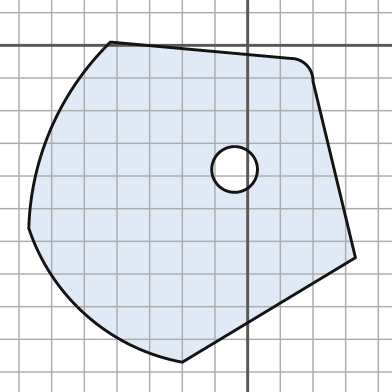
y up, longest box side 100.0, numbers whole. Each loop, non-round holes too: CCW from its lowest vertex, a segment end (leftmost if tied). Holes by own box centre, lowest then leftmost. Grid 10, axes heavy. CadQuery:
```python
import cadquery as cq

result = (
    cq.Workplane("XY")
    .moveTo(-20.0, -97.0)
    .lineTo(33.0, -65.0)
    .lineTo(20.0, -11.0)
    .threePointArc((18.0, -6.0), (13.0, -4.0))
    .lineTo(-42.0, 1.0)
    .threePointArc((-60.0, -25.0), (-67.0, -56.0))
    .threePointArc((-49.0, -83.0), (-20.0, -97.0))
    .close()
    .moveTo(-4.0, -38.0)
    .circle(7.0)
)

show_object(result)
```